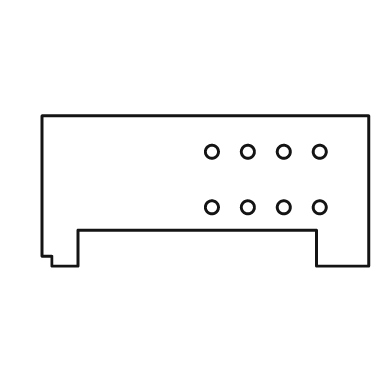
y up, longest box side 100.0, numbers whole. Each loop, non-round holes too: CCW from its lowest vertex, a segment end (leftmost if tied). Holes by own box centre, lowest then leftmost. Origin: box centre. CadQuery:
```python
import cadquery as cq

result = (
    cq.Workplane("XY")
    .moveTo(-47.0, -23.0)
    .lineTo(-39.0, -23.0)
    .lineTo(-39.0, -12.0)
    .lineTo(34.0, -12.0)
    .lineTo(34.0, -23.0)
    .lineTo(50.0, -23.0)
    .lineTo(50.0, 23.0)
    .lineTo(-50.0, 23.0)
    .lineTo(-50.0, -20.0)
    .lineTo(-47.0, -20.0)
    .close()
    .moveTo(2.0, -5.0)
    .circle(2.0)
    .moveTo(13.0, -5.0)
    .circle(2.0)
    .moveTo(24.0, -5.0)
    .circle(2.0)
    .moveTo(35.0, -5.0)
    .circle(2.0)
    .moveTo(2.0, 12.0)
    .circle(2.0)
    .moveTo(13.0, 12.0)
    .circle(2.0)
    .moveTo(24.0, 12.0)
    .circle(2.0)
    .moveTo(35.0, 12.0)
    .circle(2.0)
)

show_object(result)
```